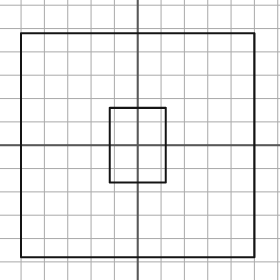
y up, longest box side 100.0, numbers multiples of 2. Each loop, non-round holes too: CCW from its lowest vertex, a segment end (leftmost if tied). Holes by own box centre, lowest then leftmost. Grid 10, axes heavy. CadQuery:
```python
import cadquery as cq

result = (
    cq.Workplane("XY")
    .moveTo(-50.0, -48.0)
    .lineTo(50.0, -48.0)
    .lineTo(50.0, 48.0)
    .lineTo(-50.0, 48.0)
    .close()
    .moveTo(-12.0, -16.0)
    .lineTo(12.0, -16.0)
    .lineTo(12.0, 16.0)
    .lineTo(-12.0, 16.0)
    .close()
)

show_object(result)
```